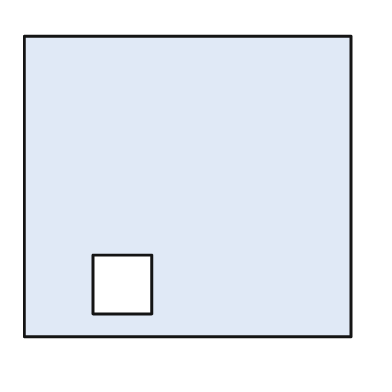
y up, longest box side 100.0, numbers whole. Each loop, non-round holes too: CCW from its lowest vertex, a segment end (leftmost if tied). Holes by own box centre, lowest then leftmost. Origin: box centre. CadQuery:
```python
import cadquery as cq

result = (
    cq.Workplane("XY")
    .moveTo(-50.0, -46.0)
    .lineTo(50.0, -46.0)
    .lineTo(50.0, 46.0)
    .lineTo(-50.0, 46.0)
    .close()
    .moveTo(-29.0, -39.0)
    .lineTo(-11.0, -39.0)
    .lineTo(-11.0, -21.0)
    .lineTo(-29.0, -21.0)
    .close()
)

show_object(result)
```